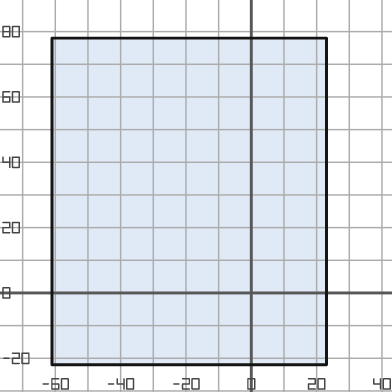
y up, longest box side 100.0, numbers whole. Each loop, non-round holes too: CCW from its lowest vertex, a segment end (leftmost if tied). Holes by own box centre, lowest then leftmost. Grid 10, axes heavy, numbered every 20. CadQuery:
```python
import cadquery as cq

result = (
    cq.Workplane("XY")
    .moveTo(-61.0, -22.0)
    .lineTo(23.0, -22.0)
    .lineTo(23.0, 78.0)
    .lineTo(-61.0, 78.0)
    .close()
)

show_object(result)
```